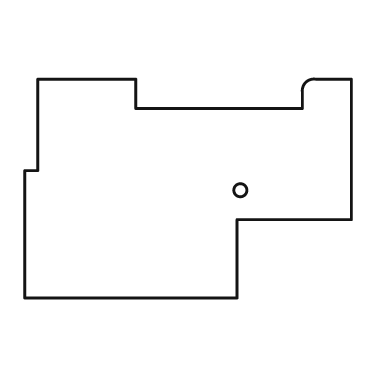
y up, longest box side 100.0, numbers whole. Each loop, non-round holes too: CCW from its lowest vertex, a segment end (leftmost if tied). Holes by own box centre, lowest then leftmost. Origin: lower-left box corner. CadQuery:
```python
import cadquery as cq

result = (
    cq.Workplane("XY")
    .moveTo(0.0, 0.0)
    .lineTo(65.0, 0.0)
    .lineTo(65.0, 24.0)
    .lineTo(100.0, 24.0)
    .lineTo(100.0, 67.0)
    .lineTo(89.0, 67.0)
    .threePointArc((86.0, 66.0), (85.0, 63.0))
    .lineTo(85.0, 58.0)
    .lineTo(34.0, 58.0)
    .lineTo(34.0, 67.0)
    .lineTo(4.0, 67.0)
    .lineTo(4.0, 39.0)
    .lineTo(0.0, 39.0)
    .close()
    .moveTo(66.0, 33.0)
    .circle(2.0)
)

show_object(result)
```